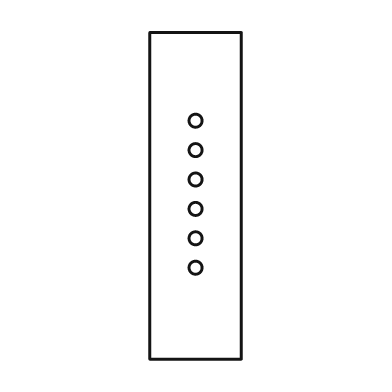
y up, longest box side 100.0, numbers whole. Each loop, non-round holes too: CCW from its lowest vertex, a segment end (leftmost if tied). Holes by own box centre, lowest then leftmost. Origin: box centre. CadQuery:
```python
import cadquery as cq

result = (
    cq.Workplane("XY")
    .moveTo(-14.0, -50.0)
    .lineTo(14.0, -50.0)
    .lineTo(14.0, 50.0)
    .lineTo(-14.0, 50.0)
    .close()
    .moveTo(0.0, -22.0)
    .circle(2.0)
    .moveTo(0.0, -13.0)
    .circle(2.0)
    .moveTo(0.0, -4.0)
    .circle(2.0)
    .moveTo(0.0, 5.0)
    .circle(2.0)
    .moveTo(0.0, 14.0)
    .circle(2.0)
    .moveTo(0.0, 23.0)
    .circle(2.0)
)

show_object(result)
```